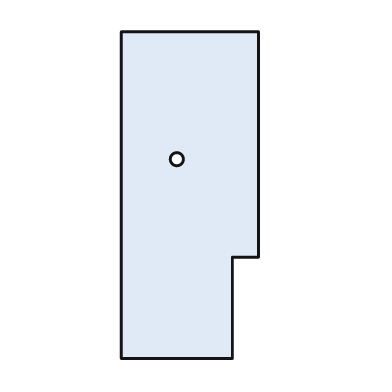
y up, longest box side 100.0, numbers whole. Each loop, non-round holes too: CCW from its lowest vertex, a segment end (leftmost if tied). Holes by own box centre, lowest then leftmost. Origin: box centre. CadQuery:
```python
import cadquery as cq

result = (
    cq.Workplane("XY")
    .moveTo(-21.0, -50.0)
    .lineTo(13.0, -50.0)
    .lineTo(13.0, -19.0)
    .lineTo(21.0, -19.0)
    .lineTo(21.0, 50.0)
    .lineTo(-21.0, 50.0)
    .close()
    .moveTo(-4.0, 11.0)
    .circle(2.0)
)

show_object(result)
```